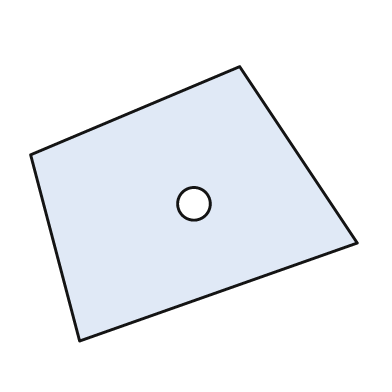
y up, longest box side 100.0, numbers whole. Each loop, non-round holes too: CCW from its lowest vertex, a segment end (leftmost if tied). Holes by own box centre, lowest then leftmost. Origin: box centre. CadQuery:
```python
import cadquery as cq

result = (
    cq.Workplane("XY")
    .moveTo(-35.0, -42.0)
    .lineTo(50.0, -12.0)
    .lineTo(14.0, 42.0)
    .lineTo(-50.0, 15.0)
    .close()
    .moveTo(0.0, 0.0)
    .circle(5.0)
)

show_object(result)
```